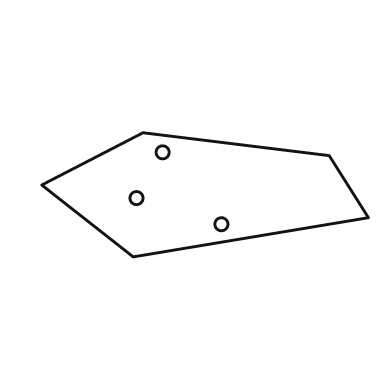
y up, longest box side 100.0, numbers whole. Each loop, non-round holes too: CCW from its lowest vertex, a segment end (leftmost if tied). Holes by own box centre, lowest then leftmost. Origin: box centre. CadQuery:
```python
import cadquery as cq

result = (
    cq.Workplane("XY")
    .moveTo(-22.0, -19.0)
    .lineTo(50.0, -7.0)
    .lineTo(38.0, 12.0)
    .lineTo(-19.0, 19.0)
    .lineTo(-50.0, 3.0)
    .close()
    .moveTo(5.0, -9.0)
    .circle(2.0)
    .moveTo(-21.0, -1.0)
    .circle(2.0)
    .moveTo(-13.0, 13.0)
    .circle(2.0)
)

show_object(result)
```